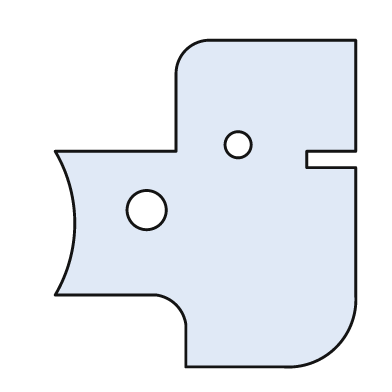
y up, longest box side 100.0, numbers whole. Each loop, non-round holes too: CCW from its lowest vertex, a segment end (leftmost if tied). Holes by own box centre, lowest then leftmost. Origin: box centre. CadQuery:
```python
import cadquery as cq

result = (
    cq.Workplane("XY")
    .moveTo(-6.0, -50.0)
    .lineTo(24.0, -50.0)
    .threePointArc((40.0, -44.0), (46.0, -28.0))
    .lineTo(46.0, 11.0)
    .lineTo(31.0, 11.0)
    .lineTo(31.0, 16.0)
    .lineTo(46.0, 16.0)
    .lineTo(46.0, 50.0)
    .lineTo(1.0, 50.0)
    .threePointArc((-6.0, 47.0), (-9.0, 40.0))
    .lineTo(-9.0, 16.0)
    .lineTo(-46.0, 16.0)
    .threePointArc((-40.0, -6.0), (-46.0, -28.0))
    .lineTo(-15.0, -28.0)
    .threePointArc((-9.0, -31.0), (-6.0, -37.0))
    .close()
    .moveTo(-18.0, -2.0)
    .circle(6.0)
    .moveTo(10.0, 18.0)
    .circle(4.0)
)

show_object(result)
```